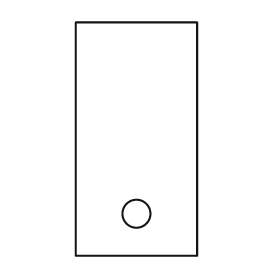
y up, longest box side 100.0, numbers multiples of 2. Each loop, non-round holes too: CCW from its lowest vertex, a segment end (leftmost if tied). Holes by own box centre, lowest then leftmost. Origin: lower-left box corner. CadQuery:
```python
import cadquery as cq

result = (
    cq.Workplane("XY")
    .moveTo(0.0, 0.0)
    .lineTo(52.0, 0.0)
    .lineTo(52.0, 100.0)
    .lineTo(0.0, 100.0)
    .close()
    .moveTo(26.0, 18.0)
    .circle(6.0)
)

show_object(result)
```